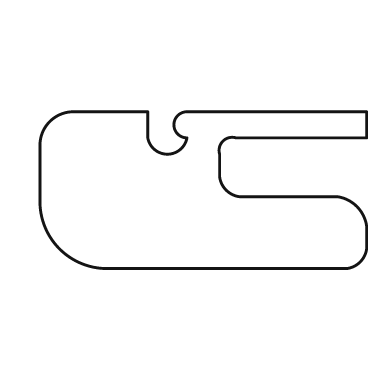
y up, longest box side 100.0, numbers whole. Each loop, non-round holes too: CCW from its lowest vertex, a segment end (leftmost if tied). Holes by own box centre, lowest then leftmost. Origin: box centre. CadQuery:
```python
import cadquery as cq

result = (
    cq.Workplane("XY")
    .moveTo(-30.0, -24.0)
    .lineTo(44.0, -24.0)
    .threePointArc((48.0, -22.0), (50.0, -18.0))
    .lineTo(50.0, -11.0)
    .threePointArc((47.0, -5.0), (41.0, -2.0))
    .lineTo(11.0, -2.0)
    .threePointArc((7.0, 0.0), (5.0, 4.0))
    .lineTo(5.0, 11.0)
    .threePointArc((6.0, 15.0), (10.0, 16.0))
    .lineTo(50.0, 16.0)
    .lineTo(50.0, 24.0)
    .lineTo(-5.0, 24.0)
    .threePointArc((-9.0, 20.0), (-5.0, 16.0))
    .threePointArc((-11.0, 11.0), (-17.0, 16.0))
    .lineTo(-17.0, 24.0)
    .lineTo(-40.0, 24.0)
    .threePointArc((-47.0, 21.0), (-50.0, 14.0))
    .lineTo(-50.0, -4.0)
    .threePointArc((-44.0, -18.0), (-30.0, -24.0))
    .close()
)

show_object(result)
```